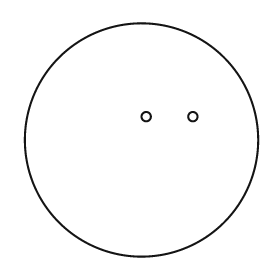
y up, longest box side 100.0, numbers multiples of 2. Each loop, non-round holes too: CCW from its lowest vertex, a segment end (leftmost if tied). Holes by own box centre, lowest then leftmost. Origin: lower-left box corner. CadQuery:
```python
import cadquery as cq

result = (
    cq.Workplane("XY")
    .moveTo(50.0, 50.0)
    .circle(50.0)
    .moveTo(52.0, 60.0)
    .circle(2.0)
    .moveTo(72.0, 60.0)
    .circle(2.0)
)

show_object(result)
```